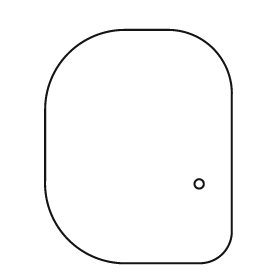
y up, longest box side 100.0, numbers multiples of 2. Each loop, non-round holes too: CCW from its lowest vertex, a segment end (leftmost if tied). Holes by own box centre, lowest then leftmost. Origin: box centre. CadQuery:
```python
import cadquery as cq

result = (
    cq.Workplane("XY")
    .moveTo(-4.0, -50.0)
    .lineTo(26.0, -50.0)
    .threePointArc((36.0, -46.0), (40.0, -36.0))
    .lineTo(40.0, 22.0)
    .threePointArc((32.0, 42.0), (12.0, 50.0))
    .lineTo(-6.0, 50.0)
    .threePointArc((-30.0, 40.0), (-40.0, 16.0))
    .lineTo(-40.0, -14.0)
    .threePointArc((-30.0, -40.0), (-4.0, -50.0))
    .close()
    .moveTo(26.0, -16.0)
    .circle(2.0)
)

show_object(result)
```